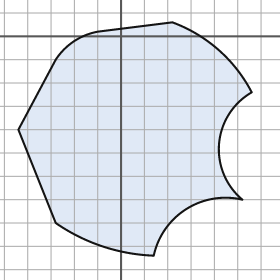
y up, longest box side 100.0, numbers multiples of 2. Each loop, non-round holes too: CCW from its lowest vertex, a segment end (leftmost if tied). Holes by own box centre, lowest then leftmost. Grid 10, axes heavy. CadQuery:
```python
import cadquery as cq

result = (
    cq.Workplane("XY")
    .moveTo(14.0, -94.0)
    .threePointArc((28.0, -74.0), (52.0, -70.0))
    .threePointArc((42.0, -46.0), (56.0, -24.0))
    .threePointArc((42.0, -6.0), (22.0, 6.0))
    .lineTo(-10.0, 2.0)
    .threePointArc((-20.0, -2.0), (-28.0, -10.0))
    .lineTo(-44.0, -40.0)
    .lineTo(-28.0, -80.0)
    .threePointArc((-8.0, -90.0), (14.0, -94.0))
    .close()
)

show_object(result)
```